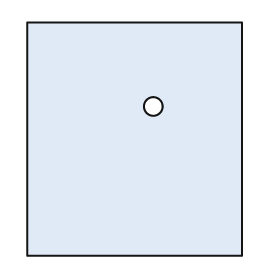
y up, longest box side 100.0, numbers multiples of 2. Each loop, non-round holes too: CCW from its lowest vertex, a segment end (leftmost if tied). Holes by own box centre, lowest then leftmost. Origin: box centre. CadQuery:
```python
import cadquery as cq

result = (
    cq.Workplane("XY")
    .moveTo(-46.0, -50.0)
    .lineTo(46.0, -50.0)
    .lineTo(46.0, 50.0)
    .lineTo(-46.0, 50.0)
    .close()
    .moveTo(8.0, 14.0)
    .circle(4.0)
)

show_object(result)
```